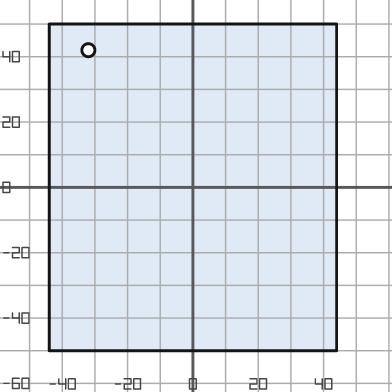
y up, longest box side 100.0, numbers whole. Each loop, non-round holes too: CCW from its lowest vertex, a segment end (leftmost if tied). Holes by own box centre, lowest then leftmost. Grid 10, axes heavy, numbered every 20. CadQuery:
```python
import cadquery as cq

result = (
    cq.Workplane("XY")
    .moveTo(-44.0, -50.0)
    .lineTo(44.0, -50.0)
    .lineTo(44.0, 50.0)
    .lineTo(-44.0, 50.0)
    .close()
    .moveTo(-32.0, 42.0)
    .circle(2.0)
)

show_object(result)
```